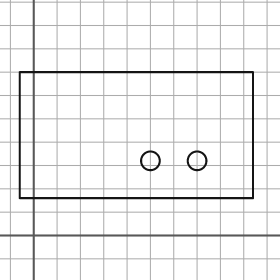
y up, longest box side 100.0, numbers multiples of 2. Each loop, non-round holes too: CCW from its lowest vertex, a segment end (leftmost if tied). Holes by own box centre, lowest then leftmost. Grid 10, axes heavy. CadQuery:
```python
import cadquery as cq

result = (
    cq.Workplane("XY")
    .moveTo(-6.0, 16.0)
    .lineTo(94.0, 16.0)
    .lineTo(94.0, 70.0)
    .lineTo(-6.0, 70.0)
    .close()
    .moveTo(50.0, 32.0)
    .circle(4.0)
    .moveTo(70.0, 32.0)
    .circle(4.0)
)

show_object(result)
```